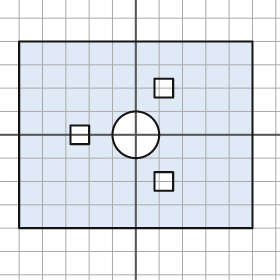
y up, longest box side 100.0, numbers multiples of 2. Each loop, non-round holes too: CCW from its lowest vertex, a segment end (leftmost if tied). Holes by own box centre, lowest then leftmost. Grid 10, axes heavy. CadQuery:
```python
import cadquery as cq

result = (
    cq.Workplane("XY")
    .moveTo(-50.0, -40.0)
    .lineTo(50.0, -40.0)
    .lineTo(50.0, 40.0)
    .lineTo(-50.0, 40.0)
    .close()
    .moveTo(8.0, -24.0)
    .lineTo(16.0, -24.0)
    .lineTo(16.0, -16.0)
    .lineTo(8.0, -16.0)
    .close()
    .moveTo(-28.0, -4.0)
    .lineTo(-20.0, -4.0)
    .lineTo(-20.0, 4.0)
    .lineTo(-28.0, 4.0)
    .close()
    .moveTo(0.0, 0.0)
    .circle(10.0)
    .moveTo(8.0, 16.0)
    .lineTo(16.0, 16.0)
    .lineTo(16.0, 24.0)
    .lineTo(8.0, 24.0)
    .close()
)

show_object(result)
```